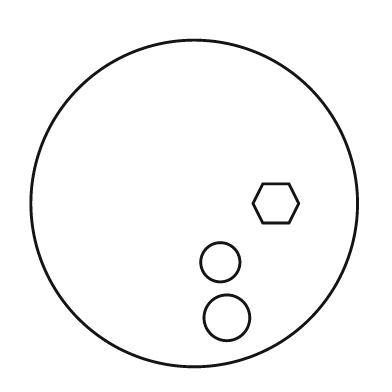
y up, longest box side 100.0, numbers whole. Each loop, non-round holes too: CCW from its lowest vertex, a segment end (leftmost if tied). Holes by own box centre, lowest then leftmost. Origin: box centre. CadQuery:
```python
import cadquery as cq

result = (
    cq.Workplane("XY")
    .moveTo(0.0, 0.0)
    .circle(50.0)
    .moveTo(10.0, -35.0)
    .circle(7.0)
    .moveTo(8.0, -18.0)
    .circle(6.0)
    .moveTo(21.0, -6.0)
    .lineTo(29.0, -6.0)
    .lineTo(32.0, 0.0)
    .lineTo(29.0, 6.0)
    .lineTo(21.0, 6.0)
    .lineTo(18.0, 0.0)
    .close()
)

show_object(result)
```